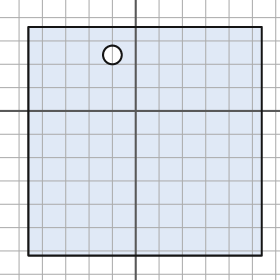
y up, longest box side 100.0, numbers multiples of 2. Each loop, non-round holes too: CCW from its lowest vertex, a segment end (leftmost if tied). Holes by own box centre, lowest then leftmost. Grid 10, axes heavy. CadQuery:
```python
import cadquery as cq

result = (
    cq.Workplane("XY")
    .moveTo(-46.0, -62.0)
    .lineTo(54.0, -62.0)
    .lineTo(54.0, 36.0)
    .lineTo(-46.0, 36.0)
    .close()
    .moveTo(-10.0, 24.0)
    .circle(4.0)
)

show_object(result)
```